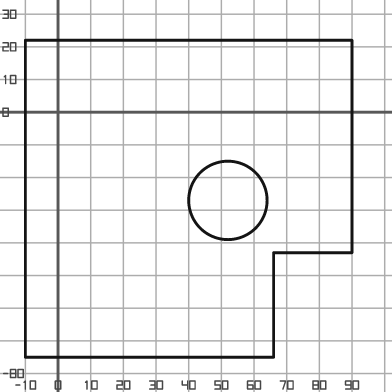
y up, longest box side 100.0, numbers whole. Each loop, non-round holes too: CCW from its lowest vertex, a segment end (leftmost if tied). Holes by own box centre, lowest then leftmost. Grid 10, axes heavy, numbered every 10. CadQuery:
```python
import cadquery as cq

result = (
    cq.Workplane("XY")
    .moveTo(-10.0, -75.0)
    .lineTo(66.0, -75.0)
    .lineTo(66.0, -43.0)
    .lineTo(90.0, -43.0)
    .lineTo(90.0, 22.0)
    .lineTo(-10.0, 22.0)
    .close()
    .moveTo(52.0, -27.0)
    .circle(12.0)
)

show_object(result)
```